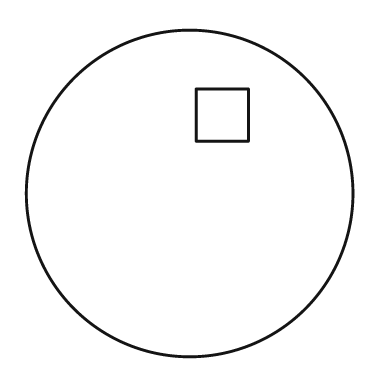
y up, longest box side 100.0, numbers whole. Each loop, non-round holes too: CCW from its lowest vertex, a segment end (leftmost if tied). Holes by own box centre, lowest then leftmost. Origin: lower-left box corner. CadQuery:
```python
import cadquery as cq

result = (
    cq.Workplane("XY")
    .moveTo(50.0, 50.0)
    .circle(50.0)
    .moveTo(52.0, 66.0)
    .lineTo(68.0, 66.0)
    .lineTo(68.0, 82.0)
    .lineTo(52.0, 82.0)
    .close()
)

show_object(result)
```